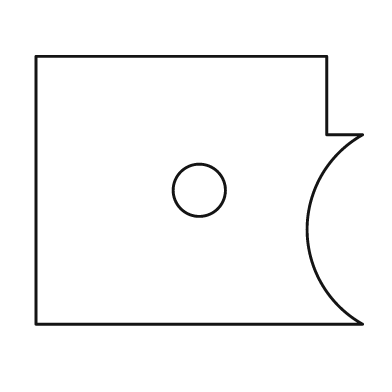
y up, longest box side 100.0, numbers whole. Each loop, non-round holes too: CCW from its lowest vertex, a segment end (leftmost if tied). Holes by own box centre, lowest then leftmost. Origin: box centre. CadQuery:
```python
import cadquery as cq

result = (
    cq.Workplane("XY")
    .moveTo(-50.0, -41.0)
    .lineTo(50.0, -41.0)
    .threePointArc((33.0, -12.0), (50.0, 17.0))
    .lineTo(39.0, 17.0)
    .lineTo(39.0, 41.0)
    .lineTo(-50.0, 41.0)
    .close()
    .moveTo(0.0, 0.0)
    .circle(8.0)
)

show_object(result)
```